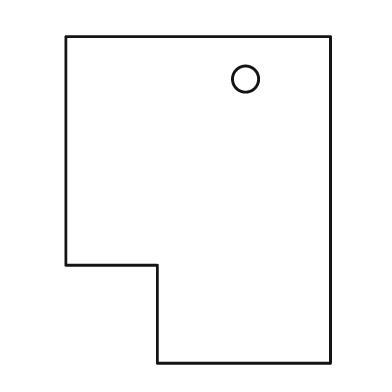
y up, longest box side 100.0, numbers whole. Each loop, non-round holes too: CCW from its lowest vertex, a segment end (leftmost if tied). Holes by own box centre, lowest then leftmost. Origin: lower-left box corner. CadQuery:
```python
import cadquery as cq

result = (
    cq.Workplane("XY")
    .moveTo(28.0, 0.0)
    .lineTo(81.0, 0.0)
    .lineTo(81.0, 100.0)
    .lineTo(0.0, 100.0)
    .lineTo(0.0, 30.0)
    .lineTo(28.0, 30.0)
    .close()
    .moveTo(55.0, 87.0)
    .circle(4.0)
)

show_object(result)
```